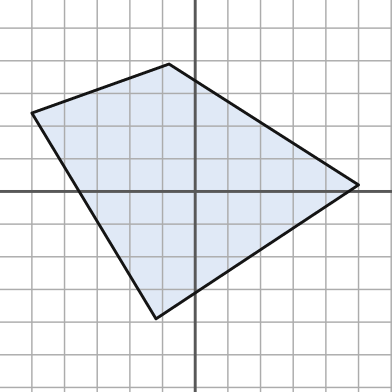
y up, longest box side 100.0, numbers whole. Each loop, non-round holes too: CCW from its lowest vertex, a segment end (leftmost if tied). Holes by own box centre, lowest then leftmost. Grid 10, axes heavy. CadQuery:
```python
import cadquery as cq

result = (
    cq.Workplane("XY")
    .moveTo(-12.0, -39.0)
    .lineTo(50.0, 2.0)
    .lineTo(-8.0, 39.0)
    .lineTo(-50.0, 24.0)
    .close()
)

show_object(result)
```